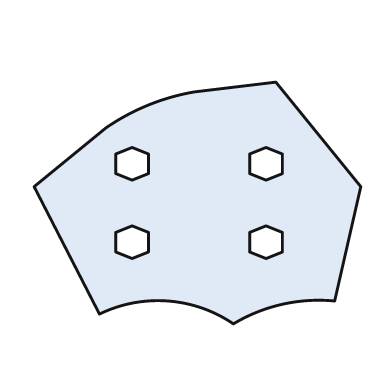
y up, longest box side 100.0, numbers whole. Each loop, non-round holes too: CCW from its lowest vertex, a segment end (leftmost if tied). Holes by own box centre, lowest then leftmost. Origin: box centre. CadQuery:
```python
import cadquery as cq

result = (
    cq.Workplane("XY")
    .moveTo(11.0, -37.0)
    .threePointArc((26.0, -31.0), (42.0, -30.0))
    .lineTo(50.0, 5.0)
    .lineTo(24.0, 37.0)
    .lineTo(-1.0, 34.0)
    .threePointArc((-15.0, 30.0), (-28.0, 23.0))
    .lineTo(-50.0, 5.0)
    .lineTo(-30.0, -34.0)
    .threePointArc((-9.0, -30.0), (11.0, -37.0))
    .close()
    .moveTo(-20.0, -17.0)
    .lineTo(-15.0, -15.0)
    .lineTo(-15.0, -9.0)
    .lineTo(-20.0, -7.0)
    .lineTo(-25.0, -9.0)
    .lineTo(-25.0, -15.0)
    .close()
    .moveTo(21.0, -17.0)
    .lineTo(26.0, -15.0)
    .lineTo(26.0, -9.0)
    .lineTo(21.0, -7.0)
    .lineTo(16.0, -9.0)
    .lineTo(16.0, -15.0)
    .close()
    .moveTo(-20.0, 7.0)
    .lineTo(-15.0, 9.0)
    .lineTo(-15.0, 15.0)
    .lineTo(-20.0, 17.0)
    .lineTo(-25.0, 15.0)
    .lineTo(-25.0, 9.0)
    .close()
    .moveTo(21.0, 7.0)
    .lineTo(26.0, 9.0)
    .lineTo(26.0, 15.0)
    .lineTo(21.0, 17.0)
    .lineTo(16.0, 15.0)
    .lineTo(16.0, 9.0)
    .close()
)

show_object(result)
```